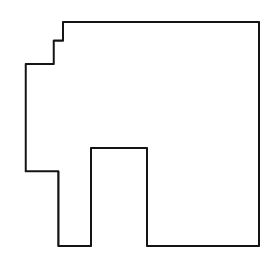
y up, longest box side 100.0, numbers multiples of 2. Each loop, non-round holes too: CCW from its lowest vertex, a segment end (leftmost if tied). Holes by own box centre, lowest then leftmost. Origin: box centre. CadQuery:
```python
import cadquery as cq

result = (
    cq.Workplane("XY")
    .moveTo(-36.0, -48.0)
    .lineTo(-22.0, -48.0)
    .lineTo(-22.0, -6.0)
    .lineTo(2.0, -6.0)
    .lineTo(2.0, -48.0)
    .lineTo(50.0, -48.0)
    .lineTo(50.0, 48.0)
    .lineTo(-34.0, 48.0)
    .lineTo(-34.0, 40.0)
    .lineTo(-38.0, 40.0)
    .lineTo(-38.0, 30.0)
    .lineTo(-50.0, 30.0)
    .lineTo(-50.0, -16.0)
    .lineTo(-36.0, -16.0)
    .close()
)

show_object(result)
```